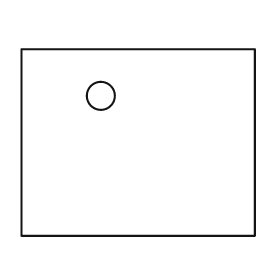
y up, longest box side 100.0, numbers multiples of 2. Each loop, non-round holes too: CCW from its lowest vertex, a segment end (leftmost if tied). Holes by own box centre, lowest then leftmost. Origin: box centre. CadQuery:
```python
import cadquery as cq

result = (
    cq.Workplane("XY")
    .moveTo(-50.0, -40.0)
    .lineTo(50.0, -40.0)
    .lineTo(50.0, 40.0)
    .lineTo(-50.0, 40.0)
    .close()
    .moveTo(-16.0, 20.0)
    .circle(6.0)
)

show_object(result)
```